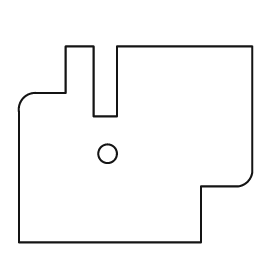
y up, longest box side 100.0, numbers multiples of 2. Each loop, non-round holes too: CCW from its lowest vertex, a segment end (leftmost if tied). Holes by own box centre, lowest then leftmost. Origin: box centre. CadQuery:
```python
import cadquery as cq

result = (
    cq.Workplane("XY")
    .moveTo(-50.0, -42.0)
    .lineTo(28.0, -42.0)
    .lineTo(28.0, -18.0)
    .lineTo(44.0, -18.0)
    .threePointArc((48.0, -16.0), (50.0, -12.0))
    .lineTo(50.0, 42.0)
    .lineTo(-8.0, 42.0)
    .lineTo(-8.0, 12.0)
    .lineTo(-18.0, 12.0)
    .lineTo(-18.0, 42.0)
    .lineTo(-30.0, 42.0)
    .lineTo(-30.0, 22.0)
    .lineTo(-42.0, 22.0)
    .threePointArc((-48.0, 20.0), (-50.0, 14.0))
    .close()
    .moveTo(-12.0, -4.0)
    .circle(4.0)
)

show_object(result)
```